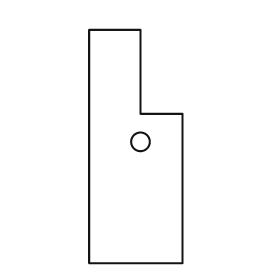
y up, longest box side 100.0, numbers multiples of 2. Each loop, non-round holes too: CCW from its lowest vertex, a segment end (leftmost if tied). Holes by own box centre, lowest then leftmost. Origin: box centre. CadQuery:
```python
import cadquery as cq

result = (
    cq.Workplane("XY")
    .moveTo(-20.0, -50.0)
    .lineTo(20.0, -50.0)
    .lineTo(20.0, 14.0)
    .lineTo(2.0, 14.0)
    .lineTo(2.0, 50.0)
    .lineTo(-20.0, 50.0)
    .close()
    .moveTo(2.0, 2.0)
    .circle(4.0)
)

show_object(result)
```